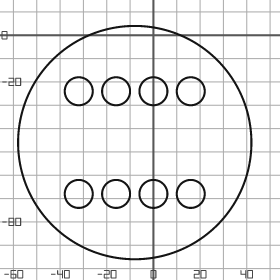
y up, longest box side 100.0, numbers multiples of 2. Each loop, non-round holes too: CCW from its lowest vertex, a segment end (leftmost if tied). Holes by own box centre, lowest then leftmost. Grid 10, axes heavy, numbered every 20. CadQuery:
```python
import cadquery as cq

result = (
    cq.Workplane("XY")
    .moveTo(-8.0, -46.0)
    .circle(50.0)
    .moveTo(-32.0, -68.0)
    .circle(6.0)
    .moveTo(-16.0, -68.0)
    .circle(6.0)
    .moveTo(0.0, -68.0)
    .circle(6.0)
    .moveTo(16.0, -68.0)
    .circle(6.0)
    .moveTo(-32.0, -24.0)
    .circle(6.0)
    .moveTo(-16.0, -24.0)
    .circle(6.0)
    .moveTo(0.0, -24.0)
    .circle(6.0)
    .moveTo(16.0, -24.0)
    .circle(6.0)
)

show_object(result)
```